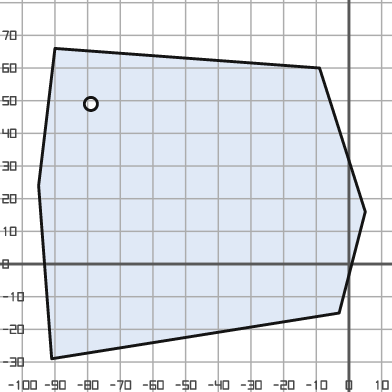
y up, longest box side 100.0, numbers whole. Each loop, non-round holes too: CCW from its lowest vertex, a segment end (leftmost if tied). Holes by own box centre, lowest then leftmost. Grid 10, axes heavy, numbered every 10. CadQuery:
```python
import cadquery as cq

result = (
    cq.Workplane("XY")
    .moveTo(-91.0, -29.0)
    .lineTo(-3.0, -15.0)
    .lineTo(5.0, 16.0)
    .lineTo(-9.0, 60.0)
    .lineTo(-90.0, 66.0)
    .lineTo(-95.0, 24.0)
    .close()
    .moveTo(-79.0, 49.0)
    .circle(2.0)
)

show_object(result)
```